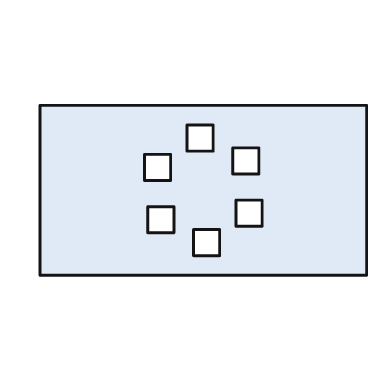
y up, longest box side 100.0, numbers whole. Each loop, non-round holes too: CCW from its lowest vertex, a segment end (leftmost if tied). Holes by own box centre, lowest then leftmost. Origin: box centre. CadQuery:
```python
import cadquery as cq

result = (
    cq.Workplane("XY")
    .moveTo(-50.0, -26.0)
    .lineTo(50.0, -26.0)
    .lineTo(50.0, 26.0)
    .lineTo(-50.0, 26.0)
    .close()
    .moveTo(-3.0, -20.0)
    .lineTo(5.0, -20.0)
    .lineTo(5.0, -12.0)
    .lineTo(-3.0, -12.0)
    .close()
    .moveTo(-17.0, -13.0)
    .lineTo(-9.0, -13.0)
    .lineTo(-9.0, -5.0)
    .lineTo(-17.0, -5.0)
    .close()
    .moveTo(10.0, -11.0)
    .lineTo(18.0, -11.0)
    .lineTo(18.0, -3.0)
    .lineTo(10.0, -3.0)
    .close()
    .moveTo(-18.0, 3.0)
    .lineTo(-10.0, 3.0)
    .lineTo(-10.0, 11.0)
    .lineTo(-18.0, 11.0)
    .close()
    .moveTo(9.0, 5.0)
    .lineTo(17.0, 5.0)
    .lineTo(17.0, 13.0)
    .lineTo(9.0, 13.0)
    .close()
    .moveTo(-5.0, 12.0)
    .lineTo(3.0, 12.0)
    .lineTo(3.0, 20.0)
    .lineTo(-5.0, 20.0)
    .close()
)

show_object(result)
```